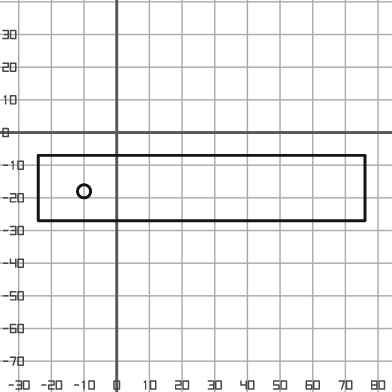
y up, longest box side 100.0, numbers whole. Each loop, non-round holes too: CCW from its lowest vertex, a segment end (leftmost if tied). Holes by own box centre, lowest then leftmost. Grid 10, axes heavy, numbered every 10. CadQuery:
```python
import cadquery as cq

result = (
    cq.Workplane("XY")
    .moveTo(-24.0, -27.0)
    .lineTo(76.0, -27.0)
    .lineTo(76.0, -7.0)
    .lineTo(-24.0, -7.0)
    .close()
    .moveTo(-10.0, -18.0)
    .circle(2.0)
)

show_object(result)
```